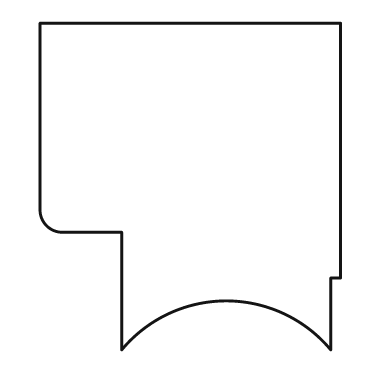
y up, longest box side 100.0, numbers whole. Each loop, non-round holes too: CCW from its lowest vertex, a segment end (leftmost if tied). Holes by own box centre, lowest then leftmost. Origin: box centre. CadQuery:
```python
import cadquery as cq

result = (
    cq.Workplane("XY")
    .moveTo(-21.0, -50.0)
    .threePointArc((11.0, -35.0), (43.0, -50.0))
    .lineTo(43.0, -28.0)
    .lineTo(46.0, -28.0)
    .lineTo(46.0, 50.0)
    .lineTo(-46.0, 50.0)
    .lineTo(-46.0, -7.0)
    .threePointArc((-44.0, -12.0), (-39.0, -14.0))
    .lineTo(-21.0, -14.0)
    .close()
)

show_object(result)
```